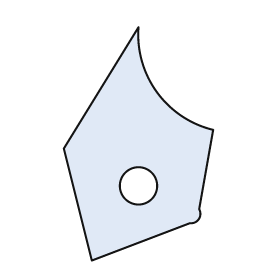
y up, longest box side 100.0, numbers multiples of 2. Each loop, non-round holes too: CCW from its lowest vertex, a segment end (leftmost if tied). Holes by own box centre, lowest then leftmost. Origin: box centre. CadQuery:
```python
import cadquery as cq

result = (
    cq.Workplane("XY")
    .moveTo(-20.0, -50.0)
    .lineTo(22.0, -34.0)
    .threePointArc((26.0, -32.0), (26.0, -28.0))
    .lineTo(32.0, 6.0)
    .threePointArc((8.0, 22.0), (0.0, 50.0))
    .lineTo(-32.0, -2.0)
    .close()
    .moveTo(0.0, -18.0)
    .circle(8.0)
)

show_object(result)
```